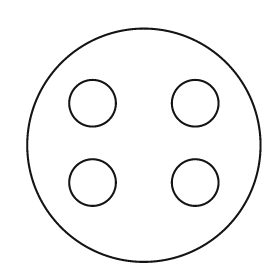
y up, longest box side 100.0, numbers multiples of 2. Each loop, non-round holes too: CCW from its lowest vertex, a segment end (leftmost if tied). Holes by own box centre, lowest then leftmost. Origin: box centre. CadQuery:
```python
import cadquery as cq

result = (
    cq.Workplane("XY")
    .moveTo(0.0, 0.0)
    .circle(50.0)
    .moveTo(-22.0, -16.0)
    .circle(10.0)
    .moveTo(22.0, -16.0)
    .circle(10.0)
    .moveTo(-22.0, 18.0)
    .circle(10.0)
    .moveTo(22.0, 18.0)
    .circle(10.0)
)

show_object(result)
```